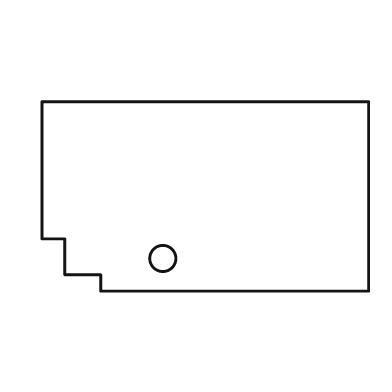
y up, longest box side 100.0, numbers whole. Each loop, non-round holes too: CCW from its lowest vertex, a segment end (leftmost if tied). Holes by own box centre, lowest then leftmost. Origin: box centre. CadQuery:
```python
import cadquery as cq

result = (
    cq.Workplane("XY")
    .moveTo(-32.0, -29.0)
    .lineTo(50.0, -29.0)
    .lineTo(50.0, 29.0)
    .lineTo(-50.0, 29.0)
    .lineTo(-50.0, -13.0)
    .lineTo(-43.0, -13.0)
    .lineTo(-43.0, -24.0)
    .lineTo(-32.0, -24.0)
    .close()
    .moveTo(-13.0, -19.0)
    .circle(4.0)
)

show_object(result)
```